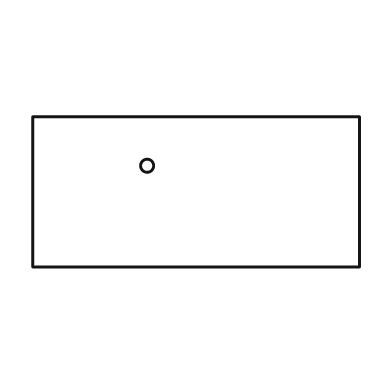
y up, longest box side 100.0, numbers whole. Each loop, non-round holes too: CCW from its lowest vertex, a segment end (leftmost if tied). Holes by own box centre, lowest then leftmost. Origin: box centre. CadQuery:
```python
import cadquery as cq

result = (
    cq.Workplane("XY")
    .moveTo(-50.0, -23.0)
    .lineTo(50.0, -23.0)
    .lineTo(50.0, 23.0)
    .lineTo(-50.0, 23.0)
    .close()
    .moveTo(-15.0, 8.0)
    .circle(2.0)
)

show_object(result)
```